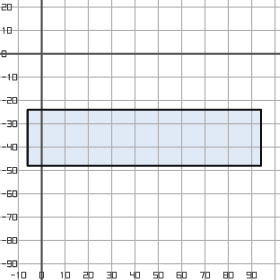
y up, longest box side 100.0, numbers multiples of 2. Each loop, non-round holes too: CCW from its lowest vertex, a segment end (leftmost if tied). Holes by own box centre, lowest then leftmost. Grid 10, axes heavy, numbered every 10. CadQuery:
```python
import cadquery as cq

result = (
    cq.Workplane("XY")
    .moveTo(-6.0, -48.0)
    .lineTo(94.0, -48.0)
    .lineTo(94.0, -24.0)
    .lineTo(-6.0, -24.0)
    .close()
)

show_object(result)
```